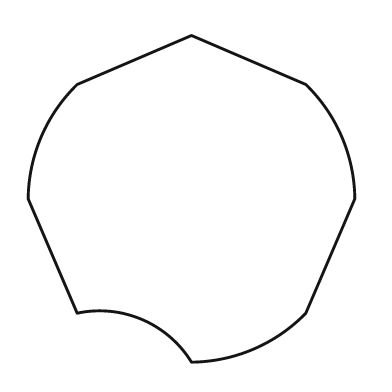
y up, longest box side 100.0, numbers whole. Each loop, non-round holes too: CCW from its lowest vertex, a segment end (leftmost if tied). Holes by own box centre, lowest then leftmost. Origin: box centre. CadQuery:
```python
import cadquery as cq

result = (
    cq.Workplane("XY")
    .moveTo(0.0, -50.0)
    .threePointArc((19.0, -46.0), (35.0, -35.0))
    .lineTo(50.0, 0.0)
    .threePointArc((46.0, 19.0), (35.0, 35.0))
    .lineTo(0.0, 50.0)
    .lineTo(-35.0, 35.0)
    .threePointArc((-46.0, 19.0), (-50.0, 0.0))
    .lineTo(-35.0, -35.0)
    .threePointArc((-15.0, -37.0), (0.0, -50.0))
    .close()
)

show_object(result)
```